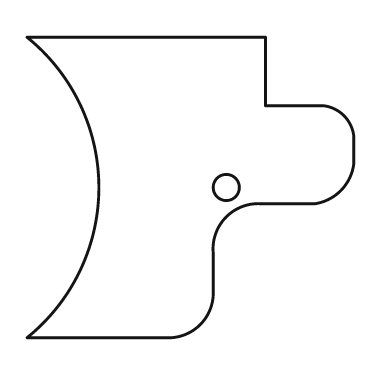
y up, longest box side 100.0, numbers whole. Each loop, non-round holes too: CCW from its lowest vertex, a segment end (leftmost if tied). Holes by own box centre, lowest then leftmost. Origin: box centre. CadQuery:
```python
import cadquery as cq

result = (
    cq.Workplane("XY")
    .moveTo(-50.0, -46.0)
    .lineTo(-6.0, -46.0)
    .threePointArc((3.0, -42.0), (7.0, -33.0))
    .lineTo(7.0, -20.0)
    .threePointArc((11.0, -9.0), (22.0, -5.0))
    .lineTo(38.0, -5.0)
    .threePointArc((46.0, -1.0), (50.0, 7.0))
    .lineTo(50.0, 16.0)
    .threePointArc((47.0, 22.0), (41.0, 25.0))
    .lineTo(23.0, 25.0)
    .lineTo(23.0, 46.0)
    .lineTo(-50.0, 46.0)
    .threePointArc((-28.0, 0.0), (-50.0, -46.0))
    .close()
    .moveTo(11.0, 0.0)
    .circle(4.0)
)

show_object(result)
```